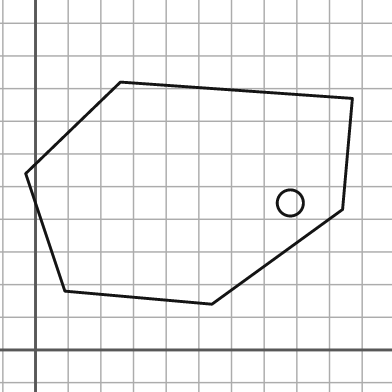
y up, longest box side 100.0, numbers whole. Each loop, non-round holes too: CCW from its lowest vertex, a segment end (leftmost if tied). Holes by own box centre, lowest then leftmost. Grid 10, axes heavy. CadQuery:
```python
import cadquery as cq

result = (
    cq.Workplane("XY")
    .moveTo(54.0, 14.0)
    .lineTo(94.0, 43.0)
    .lineTo(97.0, 77.0)
    .lineTo(26.0, 82.0)
    .lineTo(-3.0, 54.0)
    .lineTo(9.0, 18.0)
    .close()
    .moveTo(78.0, 45.0)
    .circle(4.0)
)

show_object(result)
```